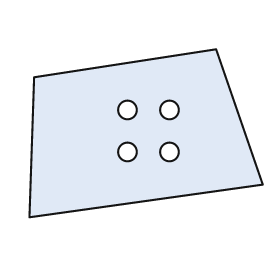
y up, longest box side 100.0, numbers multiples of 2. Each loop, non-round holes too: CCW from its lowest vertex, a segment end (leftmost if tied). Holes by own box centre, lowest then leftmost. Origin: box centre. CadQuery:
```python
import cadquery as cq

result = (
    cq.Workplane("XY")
    .moveTo(-50.0, -36.0)
    .lineTo(50.0, -22.0)
    .lineTo(30.0, 36.0)
    .lineTo(-48.0, 24.0)
    .close()
    .moveTo(-8.0, -8.0)
    .circle(4.0)
    .moveTo(10.0, -8.0)
    .circle(4.0)
    .moveTo(-8.0, 10.0)
    .circle(4.0)
    .moveTo(10.0, 10.0)
    .circle(4.0)
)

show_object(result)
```